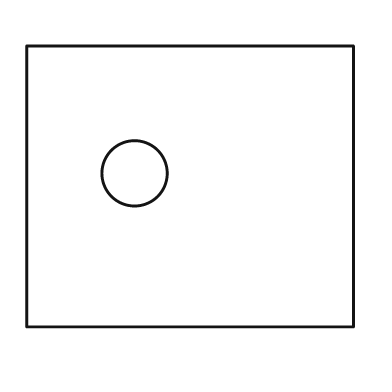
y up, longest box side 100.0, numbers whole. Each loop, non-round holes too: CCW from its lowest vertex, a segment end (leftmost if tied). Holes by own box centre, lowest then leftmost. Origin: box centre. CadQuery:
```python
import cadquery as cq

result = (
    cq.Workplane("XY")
    .moveTo(-50.0, -43.0)
    .lineTo(50.0, -43.0)
    .lineTo(50.0, 43.0)
    .lineTo(-50.0, 43.0)
    .close()
    .moveTo(-17.0, 4.0)
    .circle(10.0)
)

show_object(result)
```